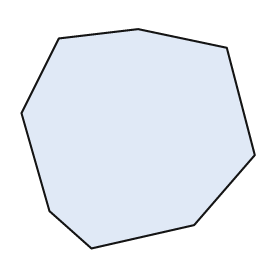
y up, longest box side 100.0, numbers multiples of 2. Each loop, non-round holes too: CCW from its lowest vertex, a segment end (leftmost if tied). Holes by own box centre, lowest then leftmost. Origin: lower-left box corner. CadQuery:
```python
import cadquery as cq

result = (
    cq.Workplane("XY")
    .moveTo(30.0, 0.0)
    .lineTo(74.0, 10.0)
    .lineTo(100.0, 40.0)
    .lineTo(88.0, 86.0)
    .lineTo(50.0, 94.0)
    .lineTo(16.0, 90.0)
    .lineTo(0.0, 58.0)
    .lineTo(12.0, 16.0)
    .close()
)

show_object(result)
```